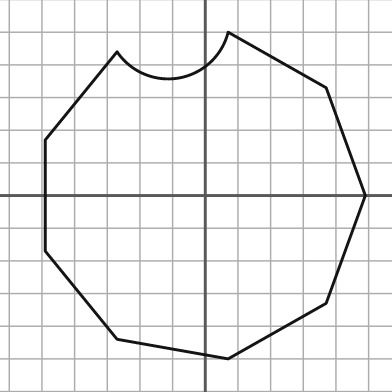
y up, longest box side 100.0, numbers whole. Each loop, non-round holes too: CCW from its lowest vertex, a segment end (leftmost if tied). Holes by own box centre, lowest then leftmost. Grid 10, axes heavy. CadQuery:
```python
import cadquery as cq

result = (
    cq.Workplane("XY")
    .moveTo(7.0, -50.0)
    .lineTo(37.0, -33.0)
    .lineTo(49.0, 0.0)
    .lineTo(37.0, 33.0)
    .lineTo(7.0, 50.0)
    .threePointArc((-8.0, 36.0), (-27.0, 44.0))
    .lineTo(-49.0, 17.0)
    .lineTo(-49.0, -17.0)
    .lineTo(-27.0, -44.0)
    .close()
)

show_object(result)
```